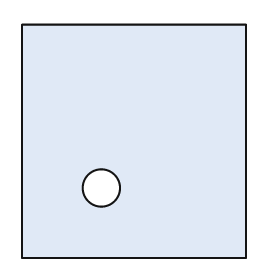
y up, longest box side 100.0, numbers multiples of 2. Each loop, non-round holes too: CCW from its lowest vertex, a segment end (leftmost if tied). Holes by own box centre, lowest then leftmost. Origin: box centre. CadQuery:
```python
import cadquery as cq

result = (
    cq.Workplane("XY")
    .moveTo(-48.0, -50.0)
    .lineTo(48.0, -50.0)
    .lineTo(48.0, 50.0)
    .lineTo(-48.0, 50.0)
    .close()
    .moveTo(-14.0, -20.0)
    .circle(8.0)
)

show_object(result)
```